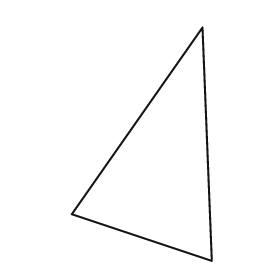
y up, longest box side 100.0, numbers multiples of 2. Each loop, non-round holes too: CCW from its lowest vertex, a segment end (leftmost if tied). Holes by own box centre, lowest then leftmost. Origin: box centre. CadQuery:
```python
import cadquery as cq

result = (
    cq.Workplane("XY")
    .moveTo(30.0, -50.0)
    .lineTo(26.0, 50.0)
    .lineTo(-30.0, -30.0)
    .close()
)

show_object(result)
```